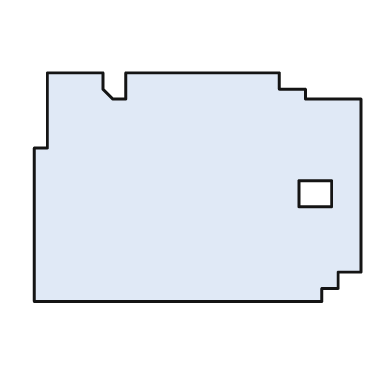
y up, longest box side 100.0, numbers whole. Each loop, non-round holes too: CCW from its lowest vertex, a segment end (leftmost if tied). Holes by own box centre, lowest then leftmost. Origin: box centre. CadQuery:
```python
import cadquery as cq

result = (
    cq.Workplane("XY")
    .moveTo(-50.0, -35.0)
    .lineTo(38.0, -35.0)
    .lineTo(38.0, -31.0)
    .lineTo(43.0, -31.0)
    .lineTo(43.0, -26.0)
    .lineTo(50.0, -26.0)
    .lineTo(50.0, 27.0)
    .lineTo(33.0, 27.0)
    .lineTo(33.0, 30.0)
    .lineTo(25.0, 30.0)
    .lineTo(25.0, 35.0)
    .lineTo(-22.0, 35.0)
    .lineTo(-22.0, 27.0)
    .lineTo(-26.0, 27.0)
    .lineTo(-29.0, 30.0)
    .lineTo(-29.0, 35.0)
    .lineTo(-46.0, 35.0)
    .lineTo(-46.0, 12.0)
    .lineTo(-50.0, 12.0)
    .close()
    .moveTo(31.0, -6.0)
    .lineTo(41.0, -6.0)
    .lineTo(41.0, 2.0)
    .lineTo(31.0, 2.0)
    .close()
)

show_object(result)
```